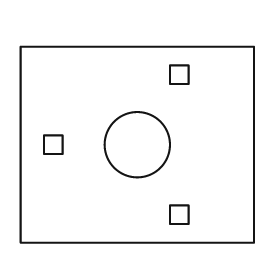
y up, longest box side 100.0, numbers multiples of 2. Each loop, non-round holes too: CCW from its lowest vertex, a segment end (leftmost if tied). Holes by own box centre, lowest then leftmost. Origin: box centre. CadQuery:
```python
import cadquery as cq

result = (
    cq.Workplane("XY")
    .moveTo(-50.0, -42.0)
    .lineTo(50.0, -42.0)
    .lineTo(50.0, 42.0)
    .lineTo(-50.0, 42.0)
    .close()
    .moveTo(14.0, -34.0)
    .lineTo(22.0, -34.0)
    .lineTo(22.0, -26.0)
    .lineTo(14.0, -26.0)
    .close()
    .moveTo(-40.0, -4.0)
    .lineTo(-32.0, -4.0)
    .lineTo(-32.0, 4.0)
    .lineTo(-40.0, 4.0)
    .close()
    .moveTo(0.0, 0.0)
    .circle(14.0)
    .moveTo(14.0, 26.0)
    .lineTo(22.0, 26.0)
    .lineTo(22.0, 34.0)
    .lineTo(14.0, 34.0)
    .close()
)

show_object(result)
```